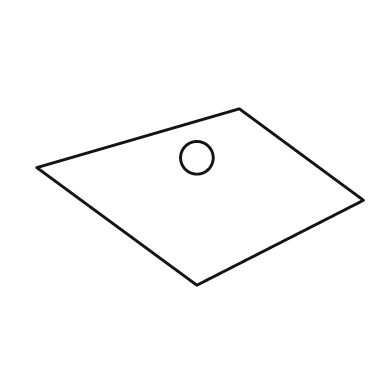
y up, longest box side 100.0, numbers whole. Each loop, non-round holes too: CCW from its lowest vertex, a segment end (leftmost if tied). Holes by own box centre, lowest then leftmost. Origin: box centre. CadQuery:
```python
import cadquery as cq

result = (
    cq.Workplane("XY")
    .moveTo(-1.0, -27.0)
    .lineTo(50.0, -1.0)
    .lineTo(12.0, 27.0)
    .lineTo(-50.0, 9.0)
    .close()
    .moveTo(-1.0, 12.0)
    .circle(5.0)
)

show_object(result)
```